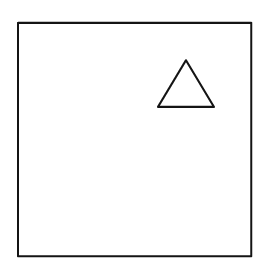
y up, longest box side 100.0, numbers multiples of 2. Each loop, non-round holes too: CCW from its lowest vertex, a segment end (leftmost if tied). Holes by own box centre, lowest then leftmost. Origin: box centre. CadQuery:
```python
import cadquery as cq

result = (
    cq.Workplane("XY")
    .moveTo(-50.0, -50.0)
    .lineTo(50.0, -50.0)
    .lineTo(50.0, 50.0)
    .lineTo(-50.0, 50.0)
    .close()
    .moveTo(10.0, 14.0)
    .lineTo(34.0, 14.0)
    .lineTo(22.0, 34.0)
    .close()
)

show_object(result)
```